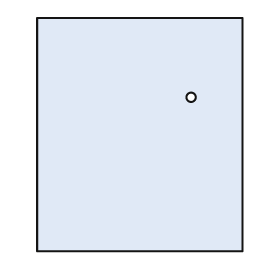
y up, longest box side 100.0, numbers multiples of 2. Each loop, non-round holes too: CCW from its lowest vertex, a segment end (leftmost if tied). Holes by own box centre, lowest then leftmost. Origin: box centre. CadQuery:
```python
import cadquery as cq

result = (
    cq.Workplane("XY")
    .moveTo(-44.0, -50.0)
    .lineTo(44.0, -50.0)
    .lineTo(44.0, 50.0)
    .lineTo(-44.0, 50.0)
    .close()
    .moveTo(22.0, 16.0)
    .circle(2.0)
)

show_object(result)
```